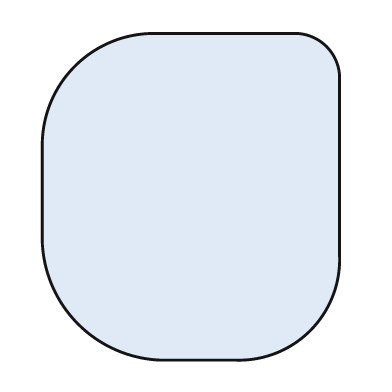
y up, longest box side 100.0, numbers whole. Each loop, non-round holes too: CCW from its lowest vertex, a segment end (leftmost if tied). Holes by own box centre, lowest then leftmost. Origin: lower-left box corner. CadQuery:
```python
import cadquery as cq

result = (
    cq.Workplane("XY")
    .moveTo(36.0, 0.0)
    .lineTo(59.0, 0.0)
    .threePointArc((82.0, 9.0), (91.0, 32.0))
    .lineTo(91.0, 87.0)
    .threePointArc((87.0, 96.0), (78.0, 100.0))
    .lineTo(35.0, 100.0)
    .threePointArc((10.0, 90.0), (0.0, 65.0))
    .lineTo(0.0, 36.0)
    .threePointArc((11.0, 11.0), (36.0, 0.0))
    .close()
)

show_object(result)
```